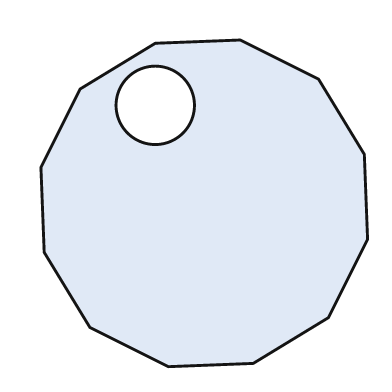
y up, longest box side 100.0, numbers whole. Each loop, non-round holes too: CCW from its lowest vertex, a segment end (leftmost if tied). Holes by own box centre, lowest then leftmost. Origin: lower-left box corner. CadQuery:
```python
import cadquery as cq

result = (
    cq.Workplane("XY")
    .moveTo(39.0, 0.0)
    .lineTo(65.0, 1.0)
    .lineTo(88.0, 15.0)
    .lineTo(100.0, 39.0)
    .lineTo(99.0, 65.0)
    .lineTo(85.0, 88.0)
    .lineTo(61.0, 100.0)
    .lineTo(35.0, 99.0)
    .lineTo(12.0, 85.0)
    .lineTo(0.0, 61.0)
    .lineTo(1.0, 35.0)
    .lineTo(15.0, 12.0)
    .close()
    .moveTo(35.0, 80.0)
    .circle(12.0)
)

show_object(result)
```